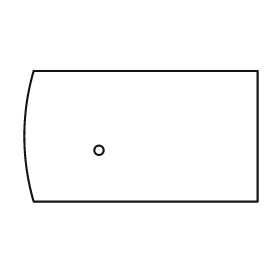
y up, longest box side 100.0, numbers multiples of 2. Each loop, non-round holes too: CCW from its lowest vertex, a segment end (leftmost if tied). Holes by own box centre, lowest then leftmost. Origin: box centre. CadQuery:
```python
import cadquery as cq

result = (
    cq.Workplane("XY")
    .moveTo(-46.0, -28.0)
    .lineTo(50.0, -28.0)
    .lineTo(50.0, 28.0)
    .lineTo(-46.0, 28.0)
    .threePointArc((-50.0, 0.0), (-46.0, -28.0))
    .close()
    .moveTo(-18.0, -6.0)
    .circle(2.0)
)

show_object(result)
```